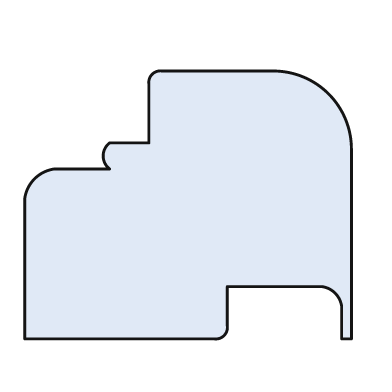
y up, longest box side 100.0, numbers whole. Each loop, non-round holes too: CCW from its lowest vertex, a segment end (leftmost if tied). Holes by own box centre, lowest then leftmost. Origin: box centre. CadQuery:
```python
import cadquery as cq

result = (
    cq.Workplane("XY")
    .moveTo(-50.0, -41.0)
    .lineTo(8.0, -41.0)
    .threePointArc((11.0, -40.0), (12.0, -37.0))
    .lineTo(12.0, -25.0)
    .lineTo(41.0, -25.0)
    .threePointArc((45.0, -27.0), (47.0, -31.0))
    .lineTo(47.0, -41.0)
    .lineTo(50.0, -41.0)
    .lineTo(50.0, 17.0)
    .threePointArc((43.0, 34.0), (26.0, 41.0))
    .lineTo(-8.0, 41.0)
    .threePointArc((-11.0, 40.0), (-12.0, 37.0))
    .lineTo(-12.0, 19.0)
    .lineTo(-24.0, 19.0)
    .threePointArc((-26.0, 15.0), (-24.0, 11.0))
    .lineTo(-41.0, 11.0)
    .threePointArc((-47.0, 8.0), (-50.0, 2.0))
    .close()
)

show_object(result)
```